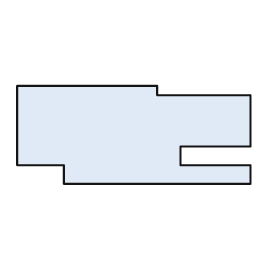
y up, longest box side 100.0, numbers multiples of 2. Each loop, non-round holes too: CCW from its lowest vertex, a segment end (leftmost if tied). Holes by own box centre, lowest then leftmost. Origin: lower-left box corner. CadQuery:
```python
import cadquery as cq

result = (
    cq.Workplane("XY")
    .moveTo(20.0, 0.0)
    .lineTo(100.0, 0.0)
    .lineTo(100.0, 8.0)
    .lineTo(70.0, 8.0)
    .lineTo(70.0, 16.0)
    .lineTo(100.0, 16.0)
    .lineTo(100.0, 38.0)
    .lineTo(60.0, 38.0)
    .lineTo(60.0, 42.0)
    .lineTo(0.0, 42.0)
    .lineTo(0.0, 8.0)
    .lineTo(20.0, 8.0)
    .close()
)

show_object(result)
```